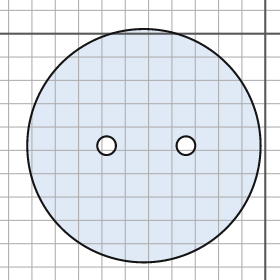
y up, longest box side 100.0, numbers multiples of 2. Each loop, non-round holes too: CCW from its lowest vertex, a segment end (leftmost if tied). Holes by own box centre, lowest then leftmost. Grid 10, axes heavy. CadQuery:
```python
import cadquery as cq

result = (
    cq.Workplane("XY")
    .moveTo(-52.0, -48.0)
    .circle(50.0)
    .moveTo(-68.0, -48.0)
    .circle(4.0)
    .moveTo(-34.0, -48.0)
    .circle(4.0)
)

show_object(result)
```